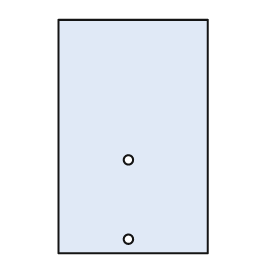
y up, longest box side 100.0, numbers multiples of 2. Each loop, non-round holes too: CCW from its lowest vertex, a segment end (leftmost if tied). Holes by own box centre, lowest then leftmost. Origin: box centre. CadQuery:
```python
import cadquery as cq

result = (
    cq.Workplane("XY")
    .moveTo(-32.0, -50.0)
    .lineTo(32.0, -50.0)
    .lineTo(32.0, 50.0)
    .lineTo(-32.0, 50.0)
    .close()
    .moveTo(-2.0, -44.0)
    .circle(2.0)
    .moveTo(-2.0, -10.0)
    .circle(2.0)
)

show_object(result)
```